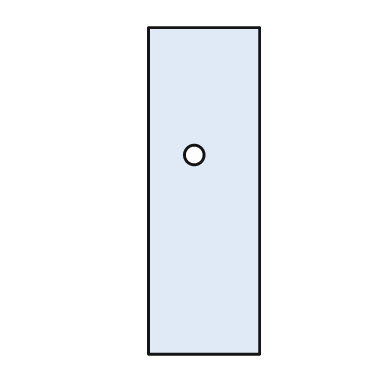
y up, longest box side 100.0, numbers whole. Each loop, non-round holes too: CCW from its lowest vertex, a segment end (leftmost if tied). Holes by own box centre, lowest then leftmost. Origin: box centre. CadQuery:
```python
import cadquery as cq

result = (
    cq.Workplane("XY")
    .moveTo(-17.0, -50.0)
    .lineTo(17.0, -50.0)
    .lineTo(17.0, 50.0)
    .lineTo(-17.0, 50.0)
    .close()
    .moveTo(-3.0, 11.0)
    .circle(3.0)
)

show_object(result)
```